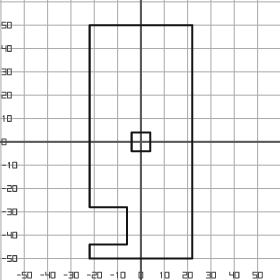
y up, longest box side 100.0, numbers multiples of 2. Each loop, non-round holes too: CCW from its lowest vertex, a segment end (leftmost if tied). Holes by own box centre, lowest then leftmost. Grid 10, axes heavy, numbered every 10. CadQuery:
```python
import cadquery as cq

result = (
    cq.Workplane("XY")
    .moveTo(-22.0, -50.0)
    .lineTo(22.0, -50.0)
    .lineTo(22.0, 50.0)
    .lineTo(-22.0, 50.0)
    .lineTo(-22.0, -28.0)
    .lineTo(-6.0, -28.0)
    .lineTo(-6.0, -44.0)
    .lineTo(-22.0, -44.0)
    .close()
    .moveTo(-4.0, -4.0)
    .lineTo(4.0, -4.0)
    .lineTo(4.0, 4.0)
    .lineTo(-4.0, 4.0)
    .close()
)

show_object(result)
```